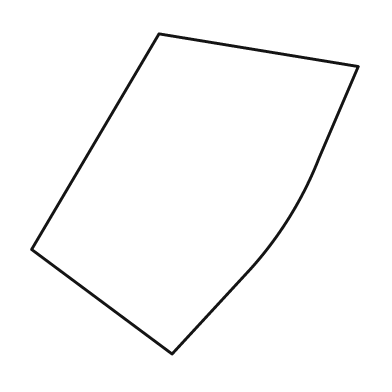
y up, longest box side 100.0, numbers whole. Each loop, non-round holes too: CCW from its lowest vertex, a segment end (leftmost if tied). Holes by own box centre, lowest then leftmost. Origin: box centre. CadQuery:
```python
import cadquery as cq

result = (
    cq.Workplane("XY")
    .moveTo(-7.0, -49.0)
    .lineTo(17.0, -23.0)
    .threePointArc((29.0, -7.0), (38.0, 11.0))
    .lineTo(50.0, 39.0)
    .lineTo(-11.0, 49.0)
    .lineTo(-50.0, -17.0)
    .close()
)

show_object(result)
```